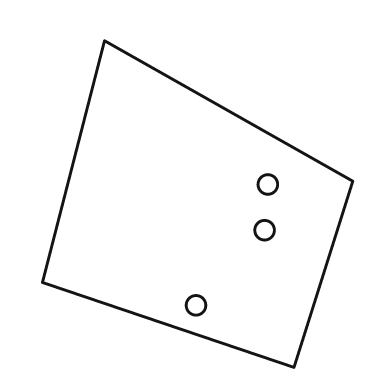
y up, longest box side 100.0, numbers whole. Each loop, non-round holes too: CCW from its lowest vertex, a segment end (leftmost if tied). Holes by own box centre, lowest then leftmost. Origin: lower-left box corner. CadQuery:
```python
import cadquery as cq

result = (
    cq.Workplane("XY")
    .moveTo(77.0, 0.0)
    .lineTo(95.0, 57.0)
    .lineTo(19.0, 100.0)
    .lineTo(0.0, 26.0)
    .close()
    .moveTo(47.0, 19.0)
    .circle(3.0)
    .moveTo(68.0, 42.0)
    .circle(3.0)
    .moveTo(69.0, 56.0)
    .circle(3.0)
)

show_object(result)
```